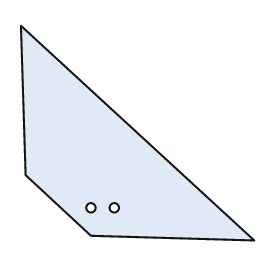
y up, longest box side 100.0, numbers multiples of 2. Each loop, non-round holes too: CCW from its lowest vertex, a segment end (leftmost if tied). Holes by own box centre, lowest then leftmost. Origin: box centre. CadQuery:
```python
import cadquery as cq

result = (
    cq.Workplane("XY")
    .moveTo(50.0, -46.0)
    .lineTo(-50.0, 46.0)
    .lineTo(-48.0, -18.0)
    .lineTo(-20.0, -44.0)
    .close()
    .moveTo(-20.0, -32.0)
    .circle(2.0)
    .moveTo(-10.0, -32.0)
    .circle(2.0)
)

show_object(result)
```